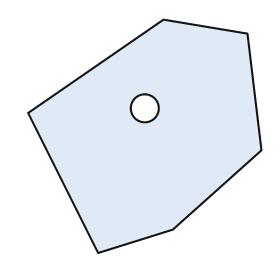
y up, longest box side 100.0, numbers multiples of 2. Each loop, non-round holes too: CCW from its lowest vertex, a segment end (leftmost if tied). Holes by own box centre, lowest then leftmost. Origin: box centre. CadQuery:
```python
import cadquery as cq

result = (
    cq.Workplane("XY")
    .moveTo(-20.0, -50.0)
    .lineTo(12.0, -40.0)
    .lineTo(50.0, -6.0)
    .lineTo(44.0, 44.0)
    .lineTo(8.0, 50.0)
    .lineTo(-50.0, 10.0)
    .close()
    .moveTo(0.0, 12.0)
    .circle(6.0)
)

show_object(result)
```